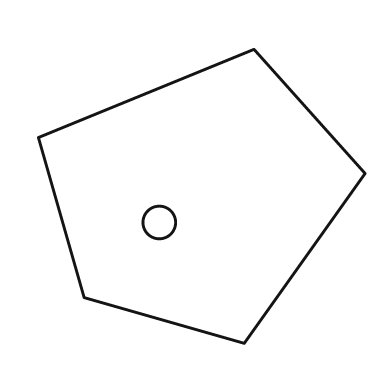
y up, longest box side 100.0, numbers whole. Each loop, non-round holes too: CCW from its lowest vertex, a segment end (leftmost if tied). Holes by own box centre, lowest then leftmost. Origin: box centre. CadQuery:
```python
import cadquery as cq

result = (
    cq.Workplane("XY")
    .moveTo(13.0, -45.0)
    .lineTo(50.0, 7.0)
    .lineTo(16.0, 45.0)
    .lineTo(-50.0, 18.0)
    .lineTo(-36.0, -31.0)
    .close()
    .moveTo(-13.0, -8.0)
    .circle(5.0)
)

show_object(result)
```